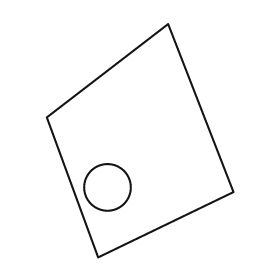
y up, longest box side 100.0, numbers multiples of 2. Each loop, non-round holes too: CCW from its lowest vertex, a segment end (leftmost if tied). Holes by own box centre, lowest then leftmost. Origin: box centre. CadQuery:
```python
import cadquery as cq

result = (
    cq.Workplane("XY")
    .moveTo(-18.0, -50.0)
    .lineTo(40.0, -22.0)
    .lineTo(12.0, 50.0)
    .lineTo(-40.0, 10.0)
    .close()
    .moveTo(-14.0, -20.0)
    .circle(10.0)
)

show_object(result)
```